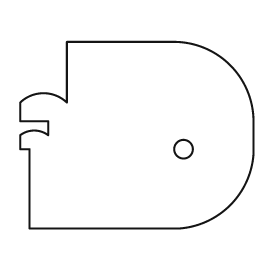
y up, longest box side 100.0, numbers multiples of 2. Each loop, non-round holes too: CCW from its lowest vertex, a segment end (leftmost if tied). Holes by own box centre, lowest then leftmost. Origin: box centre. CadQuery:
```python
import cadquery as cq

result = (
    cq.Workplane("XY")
    .moveTo(-46.0, -40.0)
    .lineTo(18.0, -40.0)
    .threePointArc((40.0, -30.0), (50.0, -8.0))
    .lineTo(50.0, 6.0)
    .threePointArc((40.0, 30.0), (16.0, 40.0))
    .lineTo(-30.0, 40.0)
    .lineTo(-30.0, 14.0)
    .threePointArc((-40.0, 18.0), (-50.0, 14.0))
    .lineTo(-50.0, 6.0)
    .lineTo(-38.0, 6.0)
    .lineTo(-38.0, 0.0)
    .threePointArc((-44.0, 2.0), (-50.0, 0.0))
    .lineTo(-50.0, -6.0)
    .lineTo(-46.0, -6.0)
    .close()
    .moveTo(20.0, -6.0)
    .circle(4.0)
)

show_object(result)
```